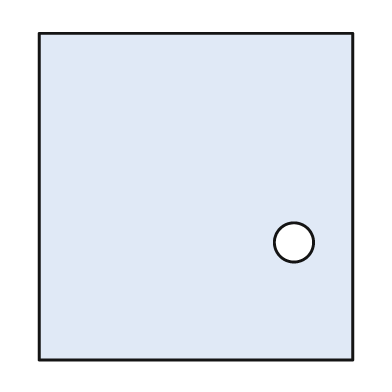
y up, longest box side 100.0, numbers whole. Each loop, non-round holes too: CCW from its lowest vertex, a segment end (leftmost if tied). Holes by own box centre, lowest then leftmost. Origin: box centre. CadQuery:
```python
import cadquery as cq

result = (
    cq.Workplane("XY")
    .moveTo(-48.0, -50.0)
    .lineTo(48.0, -50.0)
    .lineTo(48.0, 50.0)
    .lineTo(-48.0, 50.0)
    .close()
    .moveTo(30.0, -14.0)
    .circle(6.0)
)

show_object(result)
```